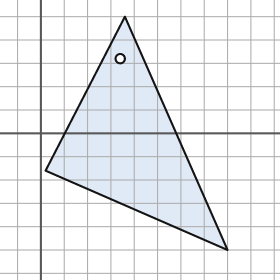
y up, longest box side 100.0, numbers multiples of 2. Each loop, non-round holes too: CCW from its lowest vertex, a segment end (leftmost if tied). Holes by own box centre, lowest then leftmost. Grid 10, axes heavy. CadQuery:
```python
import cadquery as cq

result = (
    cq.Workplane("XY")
    .moveTo(80.0, -50.0)
    .lineTo(36.0, 50.0)
    .lineTo(2.0, -16.0)
    .close()
    .moveTo(34.0, 32.0)
    .circle(2.0)
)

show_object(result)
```